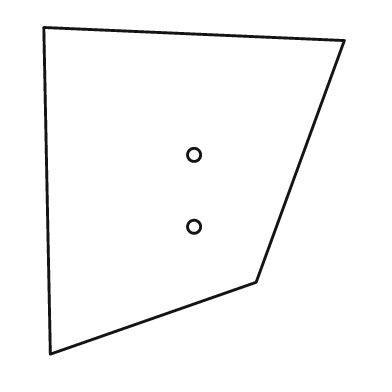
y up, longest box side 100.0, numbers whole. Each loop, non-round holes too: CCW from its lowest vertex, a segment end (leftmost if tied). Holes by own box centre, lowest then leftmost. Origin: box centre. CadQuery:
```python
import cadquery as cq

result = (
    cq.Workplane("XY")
    .moveTo(-44.0, -50.0)
    .lineTo(19.0, -28.0)
    .lineTo(46.0, 46.0)
    .lineTo(-46.0, 50.0)
    .close()
    .moveTo(0.0, -11.0)
    .circle(2.0)
    .moveTo(0.0, 11.0)
    .circle(2.0)
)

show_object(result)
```